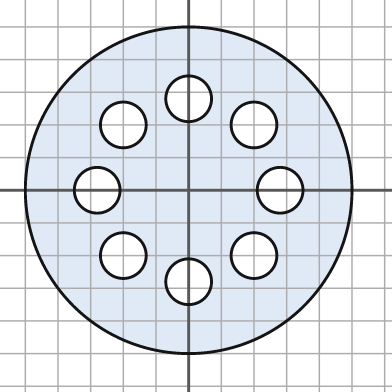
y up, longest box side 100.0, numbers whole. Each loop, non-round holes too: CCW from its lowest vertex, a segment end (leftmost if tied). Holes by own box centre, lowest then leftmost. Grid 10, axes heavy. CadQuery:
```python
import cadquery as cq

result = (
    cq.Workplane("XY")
    .moveTo(0.0, 0.0)
    .circle(50.0)
    .moveTo(0.0, -28.0)
    .circle(7.0)
    .moveTo(-20.0, -20.0)
    .circle(7.0)
    .moveTo(20.0, -20.0)
    .circle(7.0)
    .moveTo(-28.0, 0.0)
    .circle(7.0)
    .moveTo(28.0, 0.0)
    .circle(7.0)
    .moveTo(-20.0, 20.0)
    .circle(7.0)
    .moveTo(20.0, 20.0)
    .circle(7.0)
    .moveTo(0.0, 28.0)
    .circle(7.0)
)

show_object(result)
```